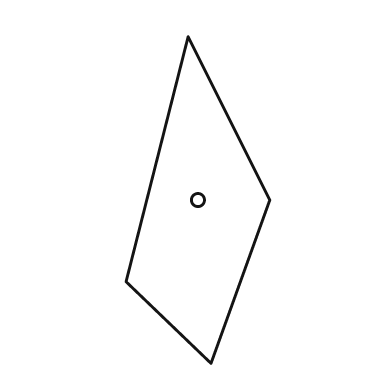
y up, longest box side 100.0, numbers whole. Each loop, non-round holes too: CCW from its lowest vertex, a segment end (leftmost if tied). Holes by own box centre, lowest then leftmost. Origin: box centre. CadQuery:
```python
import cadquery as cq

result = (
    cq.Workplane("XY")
    .moveTo(4.0, -50.0)
    .lineTo(22.0, 0.0)
    .lineTo(-3.0, 50.0)
    .lineTo(-22.0, -25.0)
    .close()
    .moveTo(0.0, 0.0)
    .circle(2.0)
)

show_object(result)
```